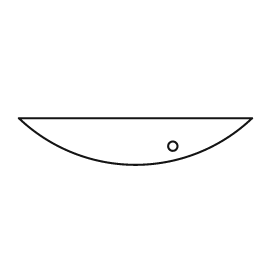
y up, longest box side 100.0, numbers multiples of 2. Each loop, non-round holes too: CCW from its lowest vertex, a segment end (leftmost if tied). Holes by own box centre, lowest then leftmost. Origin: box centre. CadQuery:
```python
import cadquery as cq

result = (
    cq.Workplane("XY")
    .moveTo(-50.0, 10.0)
    .threePointArc((0.0, -10.0), (50.0, 10.0))
    .close()
    .moveTo(16.0, -2.0)
    .circle(2.0)
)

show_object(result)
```